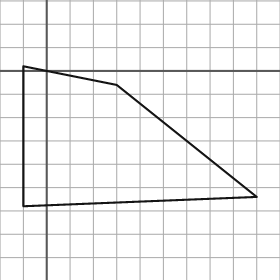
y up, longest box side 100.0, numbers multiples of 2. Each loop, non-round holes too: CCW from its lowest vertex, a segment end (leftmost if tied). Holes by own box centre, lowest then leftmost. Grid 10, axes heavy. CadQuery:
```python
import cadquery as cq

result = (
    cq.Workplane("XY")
    .moveTo(-10.0, -58.0)
    .lineTo(90.0, -54.0)
    .lineTo(30.0, -6.0)
    .lineTo(-10.0, 2.0)
    .close()
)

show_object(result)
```